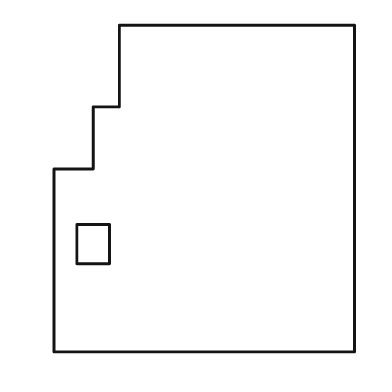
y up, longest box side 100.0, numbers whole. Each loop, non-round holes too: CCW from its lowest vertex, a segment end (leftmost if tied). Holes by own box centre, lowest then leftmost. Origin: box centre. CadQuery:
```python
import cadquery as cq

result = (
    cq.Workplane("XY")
    .moveTo(-46.0, -50.0)
    .lineTo(46.0, -50.0)
    .lineTo(46.0, 50.0)
    .lineTo(-26.0, 50.0)
    .lineTo(-26.0, 25.0)
    .lineTo(-34.0, 25.0)
    .lineTo(-34.0, 6.0)
    .lineTo(-46.0, 6.0)
    .close()
    .moveTo(-39.0, -23.0)
    .lineTo(-29.0, -23.0)
    .lineTo(-29.0, -11.0)
    .lineTo(-39.0, -11.0)
    .close()
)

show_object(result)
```